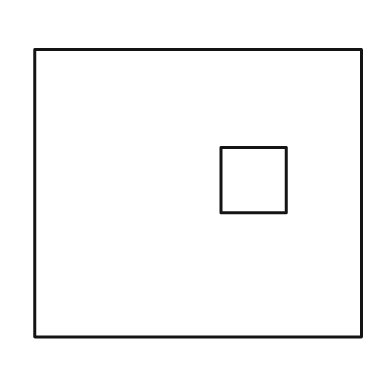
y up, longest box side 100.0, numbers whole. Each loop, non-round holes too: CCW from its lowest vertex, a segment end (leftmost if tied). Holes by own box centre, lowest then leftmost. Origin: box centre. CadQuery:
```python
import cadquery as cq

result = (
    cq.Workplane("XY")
    .moveTo(-50.0, -44.0)
    .lineTo(50.0, -44.0)
    .lineTo(50.0, 44.0)
    .lineTo(-50.0, 44.0)
    .close()
    .moveTo(7.0, -6.0)
    .lineTo(27.0, -6.0)
    .lineTo(27.0, 14.0)
    .lineTo(7.0, 14.0)
    .close()
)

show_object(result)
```